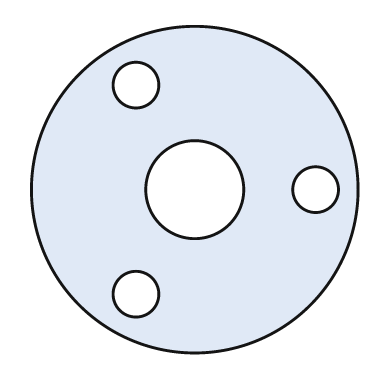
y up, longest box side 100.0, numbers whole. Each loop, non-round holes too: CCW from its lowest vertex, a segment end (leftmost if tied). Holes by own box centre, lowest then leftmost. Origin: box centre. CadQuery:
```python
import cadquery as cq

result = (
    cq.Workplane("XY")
    .moveTo(0.0, 0.0)
    .circle(50.0)
    .moveTo(-18.0, -32.0)
    .circle(7.0)
    .moveTo(0.0, 0.0)
    .circle(15.0)
    .moveTo(37.0, 0.0)
    .circle(7.0)
    .moveTo(-18.0, 32.0)
    .circle(7.0)
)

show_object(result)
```